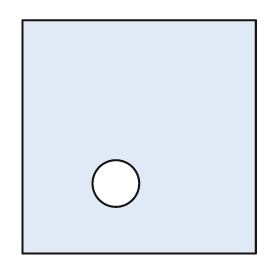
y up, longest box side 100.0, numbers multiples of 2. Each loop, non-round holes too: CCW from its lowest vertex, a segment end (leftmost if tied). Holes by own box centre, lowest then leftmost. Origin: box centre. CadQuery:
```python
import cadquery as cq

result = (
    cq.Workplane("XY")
    .moveTo(-50.0, -50.0)
    .lineTo(50.0, -50.0)
    .lineTo(50.0, 50.0)
    .lineTo(-50.0, 50.0)
    .close()
    .moveTo(-10.0, -20.0)
    .circle(10.0)
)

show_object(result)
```